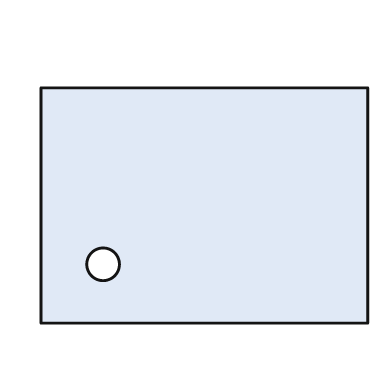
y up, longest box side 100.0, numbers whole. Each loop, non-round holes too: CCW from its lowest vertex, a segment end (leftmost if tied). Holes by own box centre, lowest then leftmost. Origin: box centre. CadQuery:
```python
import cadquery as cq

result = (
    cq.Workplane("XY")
    .moveTo(-50.0, -36.0)
    .lineTo(50.0, -36.0)
    .lineTo(50.0, 36.0)
    .lineTo(-50.0, 36.0)
    .close()
    .moveTo(-31.0, -18.0)
    .circle(5.0)
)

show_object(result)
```